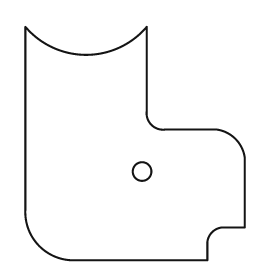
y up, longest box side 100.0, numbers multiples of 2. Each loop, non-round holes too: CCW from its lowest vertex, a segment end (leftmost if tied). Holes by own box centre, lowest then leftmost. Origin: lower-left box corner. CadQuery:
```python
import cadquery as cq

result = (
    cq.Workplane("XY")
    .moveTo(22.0, 0.0)
    .lineTo(78.0, 0.0)
    .lineTo(78.0, 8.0)
    .threePointArc((80.0, 12.0), (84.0, 14.0))
    .lineTo(94.0, 14.0)
    .lineTo(94.0, 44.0)
    .threePointArc((90.0, 52.0), (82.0, 56.0))
    .lineTo(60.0, 56.0)
    .threePointArc((54.0, 58.0), (52.0, 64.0))
    .lineTo(52.0, 100.0)
    .threePointArc((26.0, 88.0), (0.0, 100.0))
    .lineTo(0.0, 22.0)
    .threePointArc((6.0, 6.0), (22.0, 0.0))
    .close()
    .moveTo(50.0, 38.0)
    .circle(4.0)
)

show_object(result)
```